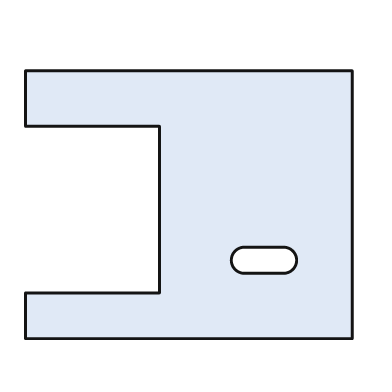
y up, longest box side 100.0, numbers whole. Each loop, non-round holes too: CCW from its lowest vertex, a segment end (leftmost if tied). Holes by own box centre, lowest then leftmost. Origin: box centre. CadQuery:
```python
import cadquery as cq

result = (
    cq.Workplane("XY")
    .moveTo(-50.0, -41.0)
    .lineTo(50.0, -41.0)
    .lineTo(50.0, 41.0)
    .lineTo(-50.0, 41.0)
    .lineTo(-50.0, 24.0)
    .lineTo(-9.0, 24.0)
    .lineTo(-9.0, -27.0)
    .lineTo(-50.0, -27.0)
    .close()
    .moveTo(17.0, -21.0)
    .lineTo(29.0, -21.0)
    .threePointArc((33.0, -17.0), (29.0, -13.0))
    .lineTo(17.0, -13.0)
    .threePointArc((13.0, -17.0), (17.0, -21.0))
    .close()
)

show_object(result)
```